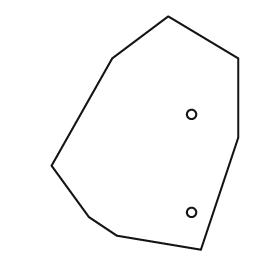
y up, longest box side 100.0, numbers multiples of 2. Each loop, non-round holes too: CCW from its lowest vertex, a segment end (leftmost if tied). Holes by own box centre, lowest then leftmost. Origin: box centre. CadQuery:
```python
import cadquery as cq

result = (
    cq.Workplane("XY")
    .moveTo(24.0, -50.0)
    .lineTo(40.0, -2.0)
    .lineTo(40.0, 32.0)
    .lineTo(10.0, 50.0)
    .lineTo(-14.0, 32.0)
    .lineTo(-40.0, -14.0)
    .lineTo(-24.0, -36.0)
    .lineTo(-12.0, -44.0)
    .close()
    .moveTo(20.0, -34.0)
    .circle(2.0)
    .moveTo(20.0, 8.0)
    .circle(2.0)
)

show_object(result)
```